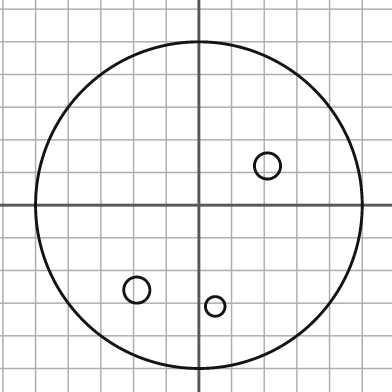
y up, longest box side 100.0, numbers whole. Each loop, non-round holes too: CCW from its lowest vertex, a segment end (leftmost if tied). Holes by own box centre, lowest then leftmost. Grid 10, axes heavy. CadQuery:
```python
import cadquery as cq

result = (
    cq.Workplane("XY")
    .moveTo(0.0, 0.0)
    .circle(50.0)
    .moveTo(5.0, -31.0)
    .circle(3.0)
    .moveTo(-19.0, -26.0)
    .circle(4.0)
    .moveTo(21.0, 12.0)
    .circle(4.0)
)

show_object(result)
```